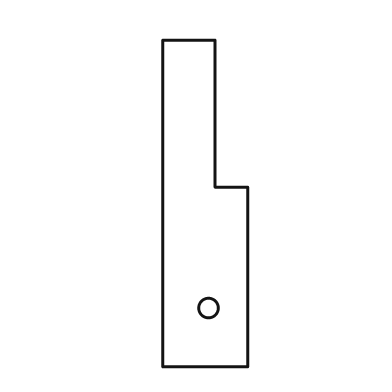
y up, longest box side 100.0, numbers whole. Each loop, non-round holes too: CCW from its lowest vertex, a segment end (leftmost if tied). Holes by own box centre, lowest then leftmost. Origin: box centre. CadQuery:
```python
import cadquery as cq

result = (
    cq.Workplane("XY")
    .moveTo(-13.0, -50.0)
    .lineTo(13.0, -50.0)
    .lineTo(13.0, 5.0)
    .lineTo(3.0, 5.0)
    .lineTo(3.0, 50.0)
    .lineTo(-13.0, 50.0)
    .close()
    .moveTo(1.0, -32.0)
    .circle(3.0)
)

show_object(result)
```